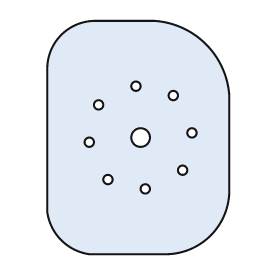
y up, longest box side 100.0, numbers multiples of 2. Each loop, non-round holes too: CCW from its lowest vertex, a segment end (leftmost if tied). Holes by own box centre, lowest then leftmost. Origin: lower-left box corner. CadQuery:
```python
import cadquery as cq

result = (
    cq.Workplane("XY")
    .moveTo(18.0, 0.0)
    .lineTo(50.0, 0.0)
    .threePointArc((70.0, 8.0), (78.0, 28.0))
    .lineTo(78.0, 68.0)
    .threePointArc((68.0, 90.0), (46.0, 100.0))
    .lineTo(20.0, 100.0)
    .threePointArc((6.0, 94.0), (0.0, 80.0))
    .lineTo(0.0, 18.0)
    .threePointArc((6.0, 6.0), (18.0, 0.0))
    .close()
    .moveTo(42.0, 28.0)
    .circle(2.0)
    .moveTo(26.0, 32.0)
    .circle(2.0)
    .moveTo(58.0, 36.0)
    .circle(2.0)
    .moveTo(18.0, 48.0)
    .circle(2.0)
    .moveTo(40.0, 50.0)
    .circle(4.0)
    .moveTo(62.0, 52.0)
    .circle(2.0)
    .moveTo(22.0, 64.0)
    .circle(2.0)
    .moveTo(54.0, 68.0)
    .circle(2.0)
    .moveTo(38.0, 72.0)
    .circle(2.0)
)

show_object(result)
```